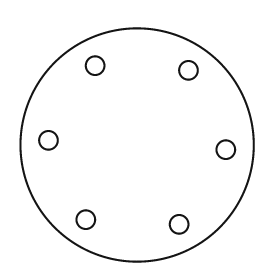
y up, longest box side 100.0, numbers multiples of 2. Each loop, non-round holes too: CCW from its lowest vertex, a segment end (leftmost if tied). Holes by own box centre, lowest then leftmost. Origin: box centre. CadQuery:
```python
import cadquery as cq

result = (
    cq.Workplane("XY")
    .moveTo(0.0, 0.0)
    .circle(50.0)
    .moveTo(18.0, -34.0)
    .circle(4.0)
    .moveTo(-22.0, -32.0)
    .circle(4.0)
    .moveTo(38.0, -2.0)
    .circle(4.0)
    .moveTo(-38.0, 2.0)
    .circle(4.0)
    .moveTo(22.0, 32.0)
    .circle(4.0)
    .moveTo(-18.0, 34.0)
    .circle(4.0)
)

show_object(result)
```